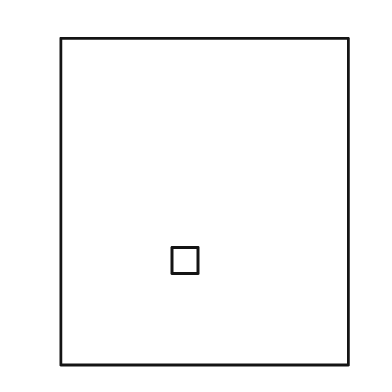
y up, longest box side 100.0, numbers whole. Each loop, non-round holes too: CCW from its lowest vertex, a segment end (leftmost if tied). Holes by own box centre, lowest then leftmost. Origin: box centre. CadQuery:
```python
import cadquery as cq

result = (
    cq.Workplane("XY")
    .moveTo(-44.0, -50.0)
    .lineTo(44.0, -50.0)
    .lineTo(44.0, 50.0)
    .lineTo(-44.0, 50.0)
    .close()
    .moveTo(-10.0, -22.0)
    .lineTo(-2.0, -22.0)
    .lineTo(-2.0, -14.0)
    .lineTo(-10.0, -14.0)
    .close()
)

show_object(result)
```